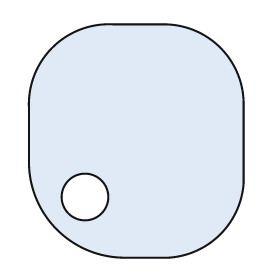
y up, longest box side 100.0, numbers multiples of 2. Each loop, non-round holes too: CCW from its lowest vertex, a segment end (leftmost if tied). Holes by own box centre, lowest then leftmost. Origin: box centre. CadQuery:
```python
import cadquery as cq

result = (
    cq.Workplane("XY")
    .moveTo(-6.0, -50.0)
    .lineTo(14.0, -50.0)
    .threePointArc((36.0, -40.0), (46.0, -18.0))
    .lineTo(46.0, 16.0)
    .threePointArc((36.0, 40.0), (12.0, 50.0))
    .lineTo(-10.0, 50.0)
    .threePointArc((-36.0, 40.0), (-46.0, 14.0))
    .lineTo(-46.0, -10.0)
    .threePointArc((-34.0, -38.0), (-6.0, -50.0))
    .close()
    .moveTo(-22.0, -24.0)
    .circle(10.0)
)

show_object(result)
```